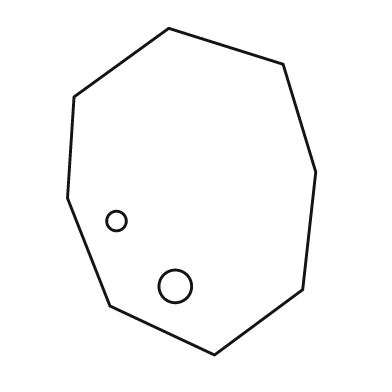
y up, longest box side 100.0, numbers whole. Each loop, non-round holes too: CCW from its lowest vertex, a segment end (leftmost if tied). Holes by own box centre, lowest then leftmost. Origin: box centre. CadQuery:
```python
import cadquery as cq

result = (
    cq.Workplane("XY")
    .moveTo(7.0, -50.0)
    .lineTo(34.0, -30.0)
    .lineTo(38.0, 6.0)
    .lineTo(28.0, 39.0)
    .lineTo(-7.0, 50.0)
    .lineTo(-36.0, 29.0)
    .lineTo(-38.0, -2.0)
    .lineTo(-25.0, -35.0)
    .close()
    .moveTo(-5.0, -29.0)
    .circle(5.0)
    .moveTo(-23.0, -9.0)
    .circle(3.0)
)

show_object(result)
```